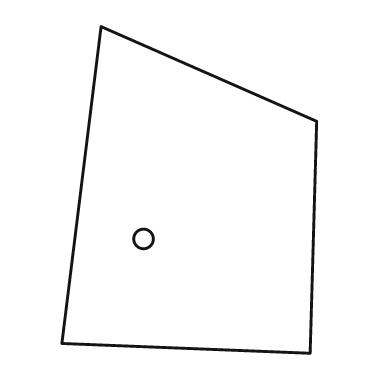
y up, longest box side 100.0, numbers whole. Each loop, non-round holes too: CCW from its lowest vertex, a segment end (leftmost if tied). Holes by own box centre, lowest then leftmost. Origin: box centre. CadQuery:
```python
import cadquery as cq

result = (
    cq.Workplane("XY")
    .moveTo(37.0, -50.0)
    .lineTo(39.0, 21.0)
    .lineTo(-27.0, 50.0)
    .lineTo(-39.0, -47.0)
    .close()
    .moveTo(-14.0, -15.0)
    .circle(3.0)
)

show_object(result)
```